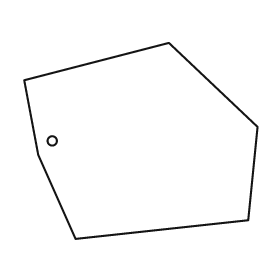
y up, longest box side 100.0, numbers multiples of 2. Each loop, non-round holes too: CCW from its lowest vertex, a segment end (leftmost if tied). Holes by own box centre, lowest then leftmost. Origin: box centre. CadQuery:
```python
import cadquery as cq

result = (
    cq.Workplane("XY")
    .moveTo(-28.0, -42.0)
    .lineTo(46.0, -34.0)
    .lineTo(50.0, 6.0)
    .lineTo(12.0, 42.0)
    .lineTo(-50.0, 26.0)
    .lineTo(-44.0, -6.0)
    .close()
    .moveTo(-38.0, 0.0)
    .circle(2.0)
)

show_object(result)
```